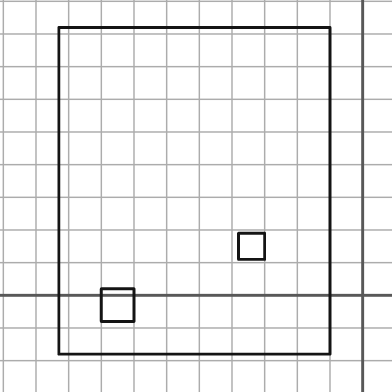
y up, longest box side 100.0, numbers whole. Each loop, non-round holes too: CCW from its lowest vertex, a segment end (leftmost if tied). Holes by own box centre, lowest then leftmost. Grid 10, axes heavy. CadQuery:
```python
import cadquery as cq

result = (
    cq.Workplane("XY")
    .moveTo(-93.0, -18.0)
    .lineTo(-10.0, -18.0)
    .lineTo(-10.0, 82.0)
    .lineTo(-93.0, 82.0)
    .close()
    .moveTo(-80.0, -8.0)
    .lineTo(-70.0, -8.0)
    .lineTo(-70.0, 2.0)
    .lineTo(-80.0, 2.0)
    .close()
    .moveTo(-38.0, 11.0)
    .lineTo(-30.0, 11.0)
    .lineTo(-30.0, 19.0)
    .lineTo(-38.0, 19.0)
    .close()
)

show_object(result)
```